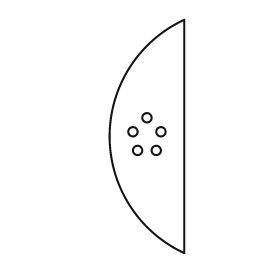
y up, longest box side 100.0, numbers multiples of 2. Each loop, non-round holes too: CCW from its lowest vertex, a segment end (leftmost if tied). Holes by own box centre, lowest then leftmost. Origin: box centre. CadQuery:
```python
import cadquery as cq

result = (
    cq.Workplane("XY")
    .moveTo(16.0, -50.0)
    .lineTo(16.0, 50.0)
    .threePointArc((-16.0, 0.0), (16.0, -50.0))
    .close()
    .moveTo(-4.0, -6.0)
    .circle(2.0)
    .moveTo(4.0, -6.0)
    .circle(2.0)
    .moveTo(-6.0, 2.0)
    .circle(2.0)
    .moveTo(6.0, 2.0)
    .circle(2.0)
    .moveTo(0.0, 8.0)
    .circle(2.0)
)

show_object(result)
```